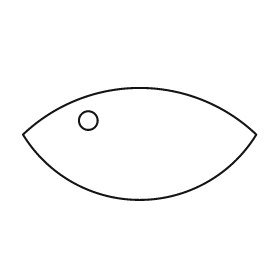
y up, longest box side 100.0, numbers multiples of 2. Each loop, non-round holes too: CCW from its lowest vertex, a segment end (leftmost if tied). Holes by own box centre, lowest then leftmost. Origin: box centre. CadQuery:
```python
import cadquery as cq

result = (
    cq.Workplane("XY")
    .moveTo(-50.0, 4.0)
    .threePointArc((0.0, -24.0), (50.0, 4.0))
    .threePointArc((0.0, 24.0), (-50.0, 4.0))
    .close()
    .moveTo(-22.0, 10.0)
    .circle(4.0)
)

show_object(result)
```